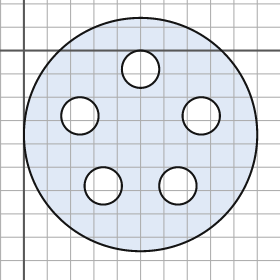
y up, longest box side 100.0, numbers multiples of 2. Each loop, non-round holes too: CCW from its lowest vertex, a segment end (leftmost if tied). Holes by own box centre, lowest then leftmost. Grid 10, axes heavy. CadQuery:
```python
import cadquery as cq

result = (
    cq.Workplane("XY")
    .moveTo(50.0, -36.0)
    .circle(50.0)
    .moveTo(34.0, -58.0)
    .circle(8.0)
    .moveTo(66.0, -58.0)
    .circle(8.0)
    .moveTo(24.0, -28.0)
    .circle(8.0)
    .moveTo(76.0, -28.0)
    .circle(8.0)
    .moveTo(50.0, -8.0)
    .circle(8.0)
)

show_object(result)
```